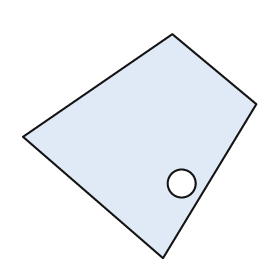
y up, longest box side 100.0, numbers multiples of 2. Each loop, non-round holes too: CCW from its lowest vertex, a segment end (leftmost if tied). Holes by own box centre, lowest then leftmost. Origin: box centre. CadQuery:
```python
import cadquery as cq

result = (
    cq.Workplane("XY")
    .moveTo(10.0, -48.0)
    .lineTo(50.0, 18.0)
    .lineTo(14.0, 48.0)
    .lineTo(-50.0, 4.0)
    .close()
    .moveTo(18.0, -16.0)
    .circle(6.0)
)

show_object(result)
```